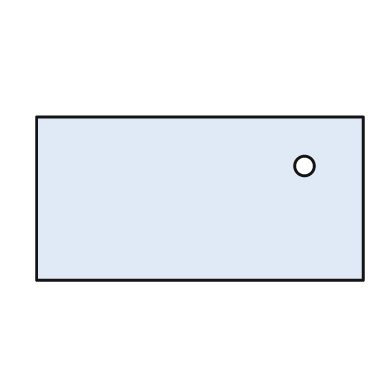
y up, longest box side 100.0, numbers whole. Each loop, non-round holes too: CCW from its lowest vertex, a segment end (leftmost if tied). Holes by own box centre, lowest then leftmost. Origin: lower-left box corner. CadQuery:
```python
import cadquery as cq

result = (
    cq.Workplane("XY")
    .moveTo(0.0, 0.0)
    .lineTo(100.0, 0.0)
    .lineTo(100.0, 50.0)
    .lineTo(0.0, 50.0)
    .close()
    .moveTo(82.0, 35.0)
    .circle(3.0)
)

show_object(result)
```